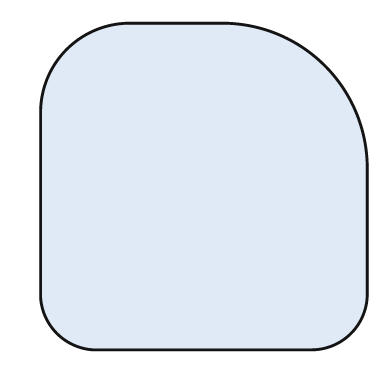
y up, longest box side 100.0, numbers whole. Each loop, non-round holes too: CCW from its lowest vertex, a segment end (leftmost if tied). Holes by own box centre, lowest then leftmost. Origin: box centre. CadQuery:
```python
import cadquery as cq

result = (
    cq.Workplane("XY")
    .moveTo(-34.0, -50.0)
    .lineTo(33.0, -50.0)
    .threePointArc((45.0, -45.0), (50.0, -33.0))
    .lineTo(50.0, 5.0)
    .threePointArc((37.0, 37.0), (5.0, 50.0))
    .lineTo(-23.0, 50.0)
    .threePointArc((-42.0, 42.0), (-50.0, 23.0))
    .lineTo(-50.0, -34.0)
    .threePointArc((-45.0, -45.0), (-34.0, -50.0))
    .close()
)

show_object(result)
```